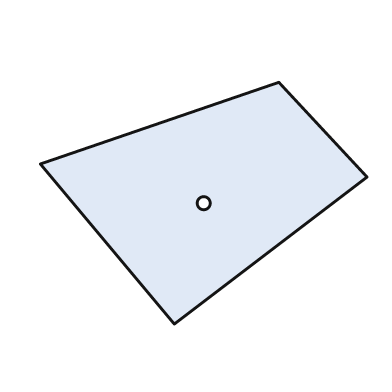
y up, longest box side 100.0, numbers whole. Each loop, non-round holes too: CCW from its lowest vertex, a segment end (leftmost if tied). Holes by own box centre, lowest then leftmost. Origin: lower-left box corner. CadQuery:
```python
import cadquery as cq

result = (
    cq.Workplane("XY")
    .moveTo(41.0, 0.0)
    .lineTo(100.0, 45.0)
    .lineTo(73.0, 74.0)
    .lineTo(0.0, 49.0)
    .close()
    .moveTo(50.0, 37.0)
    .circle(2.0)
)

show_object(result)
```